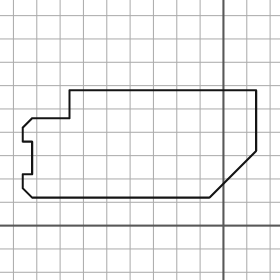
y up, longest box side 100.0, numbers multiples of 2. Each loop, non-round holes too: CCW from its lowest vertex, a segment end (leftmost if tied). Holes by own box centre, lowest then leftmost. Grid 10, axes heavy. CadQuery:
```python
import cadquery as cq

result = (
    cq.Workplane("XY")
    .moveTo(-82.0, 12.0)
    .lineTo(-6.0, 12.0)
    .lineTo(14.0, 32.0)
    .lineTo(14.0, 58.0)
    .lineTo(-66.0, 58.0)
    .lineTo(-66.0, 46.0)
    .lineTo(-82.0, 46.0)
    .lineTo(-86.0, 42.0)
    .lineTo(-86.0, 36.0)
    .lineTo(-82.0, 36.0)
    .lineTo(-82.0, 22.0)
    .lineTo(-86.0, 22.0)
    .lineTo(-86.0, 16.0)
    .close()
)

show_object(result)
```